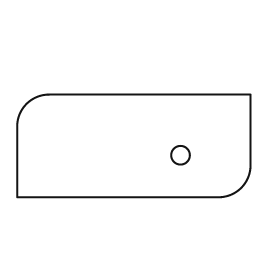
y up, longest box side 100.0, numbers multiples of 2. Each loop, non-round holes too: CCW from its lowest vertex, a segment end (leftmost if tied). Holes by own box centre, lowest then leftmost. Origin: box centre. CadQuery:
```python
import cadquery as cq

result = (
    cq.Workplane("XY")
    .moveTo(-50.0, -22.0)
    .lineTo(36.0, -22.0)
    .threePointArc((46.0, -18.0), (50.0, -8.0))
    .lineTo(50.0, 22.0)
    .lineTo(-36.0, 22.0)
    .threePointArc((-46.0, 18.0), (-50.0, 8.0))
    .close()
    .moveTo(20.0, -4.0)
    .circle(4.0)
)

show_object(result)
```